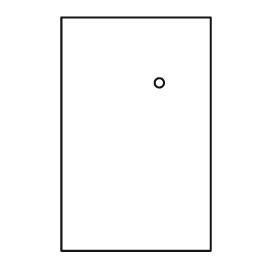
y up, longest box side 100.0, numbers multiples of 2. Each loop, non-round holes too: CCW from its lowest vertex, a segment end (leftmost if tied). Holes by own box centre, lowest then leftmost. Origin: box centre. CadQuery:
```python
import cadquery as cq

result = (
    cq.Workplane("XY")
    .moveTo(-32.0, -50.0)
    .lineTo(32.0, -50.0)
    .lineTo(32.0, 50.0)
    .lineTo(-32.0, 50.0)
    .close()
    .moveTo(10.0, 22.0)
    .circle(2.0)
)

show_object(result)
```